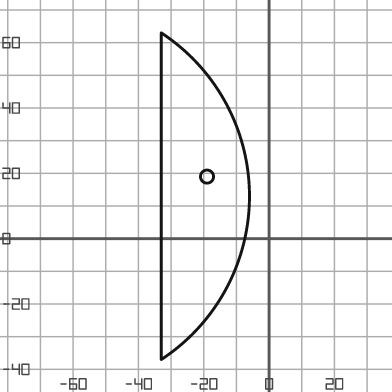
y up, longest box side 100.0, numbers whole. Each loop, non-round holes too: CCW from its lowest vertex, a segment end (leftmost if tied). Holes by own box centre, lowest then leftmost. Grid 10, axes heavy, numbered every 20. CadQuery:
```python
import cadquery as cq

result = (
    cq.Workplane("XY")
    .moveTo(-33.0, -37.0)
    .threePointArc((-6.0, 13.0), (-33.0, 63.0))
    .close()
    .moveTo(-19.0, 19.0)
    .circle(2.0)
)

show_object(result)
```